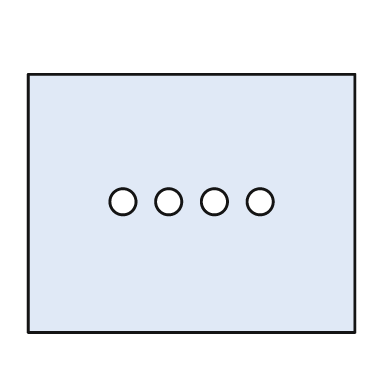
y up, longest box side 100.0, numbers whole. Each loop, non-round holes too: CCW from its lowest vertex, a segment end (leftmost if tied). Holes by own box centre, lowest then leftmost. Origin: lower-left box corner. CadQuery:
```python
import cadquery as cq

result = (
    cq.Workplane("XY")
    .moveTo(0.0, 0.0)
    .lineTo(100.0, 0.0)
    .lineTo(100.0, 79.0)
    .lineTo(0.0, 79.0)
    .close()
    .moveTo(29.0, 40.0)
    .circle(4.0)
    .moveTo(43.0, 40.0)
    .circle(4.0)
    .moveTo(57.0, 40.0)
    .circle(4.0)
    .moveTo(71.0, 40.0)
    .circle(4.0)
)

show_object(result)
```